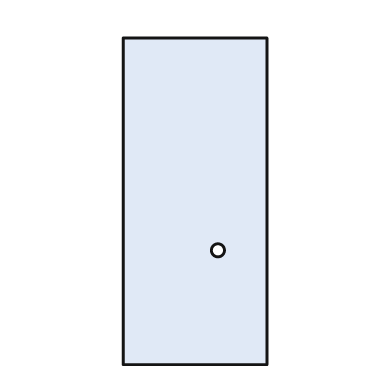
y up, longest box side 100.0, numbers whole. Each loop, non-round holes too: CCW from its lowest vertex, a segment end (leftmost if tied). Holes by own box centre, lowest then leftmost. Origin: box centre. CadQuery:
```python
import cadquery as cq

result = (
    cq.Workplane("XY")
    .moveTo(-22.0, -50.0)
    .lineTo(22.0, -50.0)
    .lineTo(22.0, 50.0)
    .lineTo(-22.0, 50.0)
    .close()
    .moveTo(7.0, -15.0)
    .circle(2.0)
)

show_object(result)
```